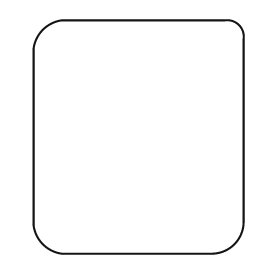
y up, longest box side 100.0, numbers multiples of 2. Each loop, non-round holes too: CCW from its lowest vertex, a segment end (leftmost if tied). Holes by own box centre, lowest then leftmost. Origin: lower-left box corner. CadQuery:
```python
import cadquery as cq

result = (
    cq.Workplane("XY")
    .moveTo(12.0, 0.0)
    .lineTo(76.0, 0.0)
    .threePointArc((86.0, 4.0), (90.0, 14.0))
    .lineTo(90.0, 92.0)
    .threePointArc((88.0, 98.0), (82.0, 100.0))
    .lineTo(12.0, 100.0)
    .threePointArc((4.0, 96.0), (0.0, 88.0))
    .lineTo(0.0, 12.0)
    .threePointArc((4.0, 4.0), (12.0, 0.0))
    .close()
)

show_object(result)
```